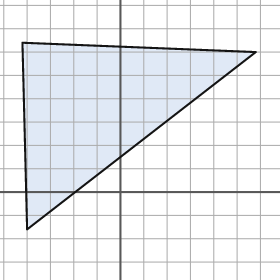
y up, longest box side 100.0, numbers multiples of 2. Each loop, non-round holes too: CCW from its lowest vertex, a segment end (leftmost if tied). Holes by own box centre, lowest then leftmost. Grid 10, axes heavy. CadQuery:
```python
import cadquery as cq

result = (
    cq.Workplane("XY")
    .moveTo(-40.0, -16.0)
    .lineTo(58.0, 60.0)
    .lineTo(-42.0, 64.0)
    .close()
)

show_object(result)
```